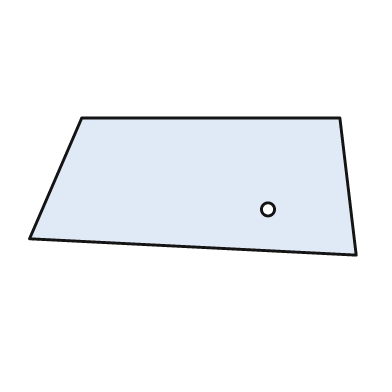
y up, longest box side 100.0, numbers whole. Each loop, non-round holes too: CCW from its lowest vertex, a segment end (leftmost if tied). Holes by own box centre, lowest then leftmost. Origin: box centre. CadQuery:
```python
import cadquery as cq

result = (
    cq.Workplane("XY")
    .moveTo(50.0, -21.0)
    .lineTo(45.0, 21.0)
    .lineTo(-34.0, 21.0)
    .lineTo(-50.0, -16.0)
    .close()
    .moveTo(23.0, -7.0)
    .circle(2.0)
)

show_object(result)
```